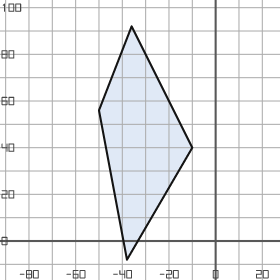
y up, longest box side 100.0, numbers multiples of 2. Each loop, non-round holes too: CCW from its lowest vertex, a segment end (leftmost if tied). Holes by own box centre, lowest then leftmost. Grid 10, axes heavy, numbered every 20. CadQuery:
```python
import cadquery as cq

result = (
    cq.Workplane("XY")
    .moveTo(-38.0, -8.0)
    .lineTo(-10.0, 40.0)
    .lineTo(-36.0, 92.0)
    .lineTo(-50.0, 56.0)
    .close()
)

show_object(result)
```